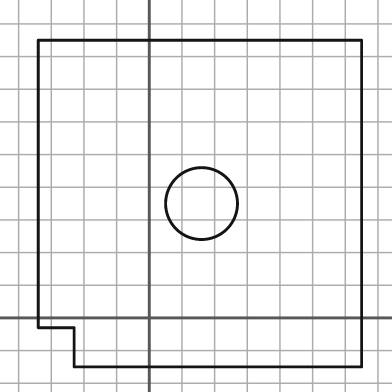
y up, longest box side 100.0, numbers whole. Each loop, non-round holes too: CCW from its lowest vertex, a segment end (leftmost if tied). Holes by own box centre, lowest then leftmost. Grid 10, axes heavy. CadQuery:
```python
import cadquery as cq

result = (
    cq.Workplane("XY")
    .moveTo(-23.0, -15.0)
    .lineTo(65.0, -15.0)
    .lineTo(65.0, 85.0)
    .lineTo(-34.0, 85.0)
    .lineTo(-34.0, -3.0)
    .lineTo(-23.0, -3.0)
    .close()
    .moveTo(16.0, 35.0)
    .circle(11.0)
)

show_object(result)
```